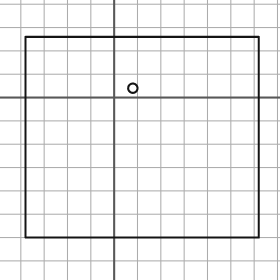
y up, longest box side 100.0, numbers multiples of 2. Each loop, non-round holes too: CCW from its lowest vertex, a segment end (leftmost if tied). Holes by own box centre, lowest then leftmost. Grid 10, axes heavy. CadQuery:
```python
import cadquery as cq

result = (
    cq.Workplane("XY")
    .moveTo(-38.0, -60.0)
    .lineTo(62.0, -60.0)
    .lineTo(62.0, 26.0)
    .lineTo(-38.0, 26.0)
    .close()
    .moveTo(8.0, 4.0)
    .circle(2.0)
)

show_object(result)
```